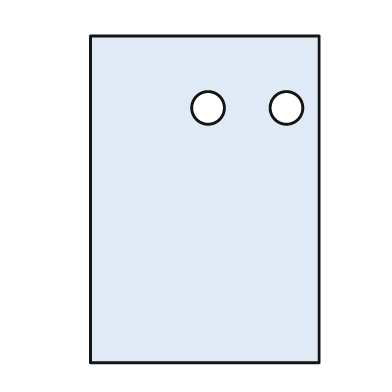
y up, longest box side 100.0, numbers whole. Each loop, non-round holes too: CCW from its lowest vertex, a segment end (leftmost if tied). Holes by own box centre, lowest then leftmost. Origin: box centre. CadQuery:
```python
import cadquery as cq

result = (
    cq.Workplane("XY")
    .moveTo(-35.0, -50.0)
    .lineTo(35.0, -50.0)
    .lineTo(35.0, 50.0)
    .lineTo(-35.0, 50.0)
    .close()
    .moveTo(1.0, 28.0)
    .circle(5.0)
    .moveTo(25.0, 28.0)
    .circle(5.0)
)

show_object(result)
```